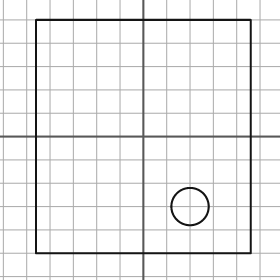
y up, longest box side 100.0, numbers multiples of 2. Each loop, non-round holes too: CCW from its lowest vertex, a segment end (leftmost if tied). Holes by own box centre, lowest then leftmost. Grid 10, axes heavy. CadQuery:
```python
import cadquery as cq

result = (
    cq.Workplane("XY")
    .moveTo(-46.0, -50.0)
    .lineTo(46.0, -50.0)
    .lineTo(46.0, 50.0)
    .lineTo(-46.0, 50.0)
    .close()
    .moveTo(20.0, -30.0)
    .circle(8.0)
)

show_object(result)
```